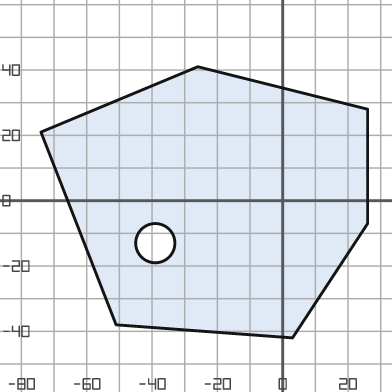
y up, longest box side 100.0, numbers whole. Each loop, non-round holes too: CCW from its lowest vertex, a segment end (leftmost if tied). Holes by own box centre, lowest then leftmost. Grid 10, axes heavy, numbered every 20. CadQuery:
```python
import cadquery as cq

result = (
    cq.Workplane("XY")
    .moveTo(3.0, -42.0)
    .lineTo(26.0, -7.0)
    .lineTo(26.0, 28.0)
    .lineTo(-26.0, 41.0)
    .lineTo(-74.0, 21.0)
    .lineTo(-51.0, -38.0)
    .close()
    .moveTo(-39.0, -13.0)
    .circle(6.0)
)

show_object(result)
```